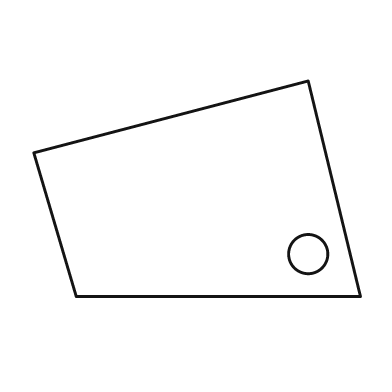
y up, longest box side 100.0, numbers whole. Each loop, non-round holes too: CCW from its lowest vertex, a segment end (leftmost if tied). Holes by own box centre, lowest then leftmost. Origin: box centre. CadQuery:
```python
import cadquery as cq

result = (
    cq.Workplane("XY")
    .moveTo(-37.0, -33.0)
    .lineTo(50.0, -33.0)
    .lineTo(34.0, 33.0)
    .lineTo(-50.0, 11.0)
    .close()
    .moveTo(34.0, -20.0)
    .circle(6.0)
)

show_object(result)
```